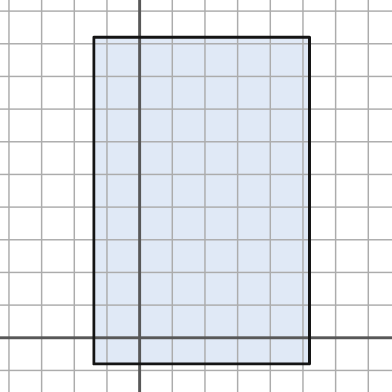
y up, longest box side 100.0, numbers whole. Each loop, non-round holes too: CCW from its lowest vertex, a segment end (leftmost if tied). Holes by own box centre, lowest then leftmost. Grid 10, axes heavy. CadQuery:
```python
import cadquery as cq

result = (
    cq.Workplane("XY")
    .moveTo(-14.0, -8.0)
    .lineTo(52.0, -8.0)
    .lineTo(52.0, 92.0)
    .lineTo(-14.0, 92.0)
    .close()
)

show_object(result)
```